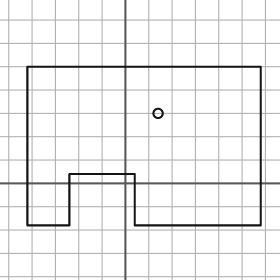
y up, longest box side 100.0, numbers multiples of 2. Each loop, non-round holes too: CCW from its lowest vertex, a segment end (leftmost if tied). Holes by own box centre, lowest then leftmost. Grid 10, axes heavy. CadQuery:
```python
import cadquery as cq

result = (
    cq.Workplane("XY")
    .moveTo(-42.0, -18.0)
    .lineTo(-24.0, -18.0)
    .lineTo(-24.0, 4.0)
    .lineTo(4.0, 4.0)
    .lineTo(4.0, -18.0)
    .lineTo(58.0, -18.0)
    .lineTo(58.0, 50.0)
    .lineTo(-42.0, 50.0)
    .close()
    .moveTo(14.0, 30.0)
    .circle(2.0)
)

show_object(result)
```